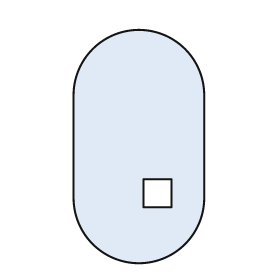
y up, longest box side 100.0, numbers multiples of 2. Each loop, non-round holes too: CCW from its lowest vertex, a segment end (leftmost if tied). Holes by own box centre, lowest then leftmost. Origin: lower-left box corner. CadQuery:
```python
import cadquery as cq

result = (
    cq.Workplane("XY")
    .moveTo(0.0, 28.0)
    .threePointArc((28.0, 0.0), (56.0, 28.0))
    .lineTo(56.0, 72.0)
    .threePointArc((28.0, 100.0), (0.0, 72.0))
    .close()
    .moveTo(30.0, 24.0)
    .lineTo(42.0, 24.0)
    .lineTo(42.0, 36.0)
    .lineTo(30.0, 36.0)
    .close()
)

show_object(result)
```